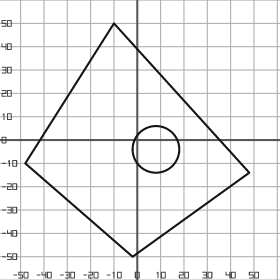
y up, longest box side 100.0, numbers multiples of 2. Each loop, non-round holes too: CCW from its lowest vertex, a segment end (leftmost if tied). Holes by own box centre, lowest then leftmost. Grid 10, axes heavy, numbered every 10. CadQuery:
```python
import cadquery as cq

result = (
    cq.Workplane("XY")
    .moveTo(-2.0, -50.0)
    .lineTo(48.0, -14.0)
    .lineTo(-10.0, 50.0)
    .lineTo(-48.0, -10.0)
    .close()
    .moveTo(8.0, -4.0)
    .circle(10.0)
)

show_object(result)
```